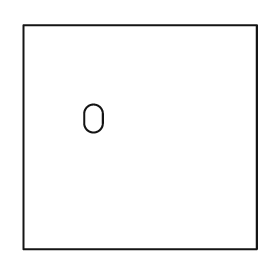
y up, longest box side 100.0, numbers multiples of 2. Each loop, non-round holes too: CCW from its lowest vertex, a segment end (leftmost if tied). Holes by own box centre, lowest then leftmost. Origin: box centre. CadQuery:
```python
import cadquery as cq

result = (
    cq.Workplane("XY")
    .moveTo(-50.0, -48.0)
    .lineTo(50.0, -48.0)
    .lineTo(50.0, 48.0)
    .lineTo(-50.0, 48.0)
    .close()
    .moveTo(-24.0, 6.0)
    .threePointArc((-20.0, 2.0), (-16.0, 6.0))
    .lineTo(-16.0, 10.0)
    .threePointArc((-20.0, 14.0), (-24.0, 10.0))
    .close()
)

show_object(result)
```